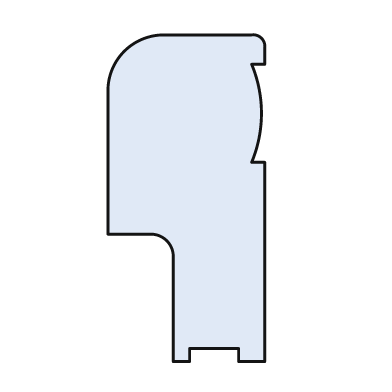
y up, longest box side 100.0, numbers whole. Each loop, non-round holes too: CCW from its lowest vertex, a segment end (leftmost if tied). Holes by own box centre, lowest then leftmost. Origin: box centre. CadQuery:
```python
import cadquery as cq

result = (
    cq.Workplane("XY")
    .moveTo(-4.0, -50.0)
    .lineTo(1.0, -50.0)
    .lineTo(1.0, -46.0)
    .lineTo(16.0, -46.0)
    .lineTo(16.0, -50.0)
    .lineTo(24.0, -50.0)
    .lineTo(24.0, 11.0)
    .lineTo(20.0, 11.0)
    .threePointArc((23.0, 26.0), (20.0, 41.0))
    .lineTo(24.0, 41.0)
    .lineTo(24.0, 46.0)
    .threePointArc((23.0, 49.0), (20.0, 50.0))
    .lineTo(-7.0, 50.0)
    .threePointArc((-19.0, 45.0), (-24.0, 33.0))
    .lineTo(-24.0, -11.0)
    .lineTo(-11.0, -11.0)
    .threePointArc((-6.0, -13.0), (-4.0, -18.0))
    .close()
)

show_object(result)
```